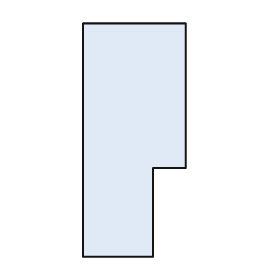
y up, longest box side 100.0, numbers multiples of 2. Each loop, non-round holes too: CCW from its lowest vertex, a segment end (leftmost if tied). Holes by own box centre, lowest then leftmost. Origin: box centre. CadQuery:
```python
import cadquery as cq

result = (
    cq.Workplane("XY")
    .moveTo(-22.0, -50.0)
    .lineTo(8.0, -50.0)
    .lineTo(8.0, -12.0)
    .lineTo(22.0, -12.0)
    .lineTo(22.0, 50.0)
    .lineTo(-22.0, 50.0)
    .close()
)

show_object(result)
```